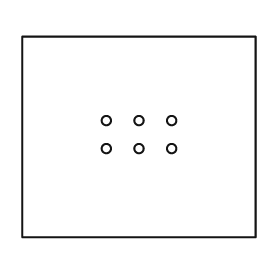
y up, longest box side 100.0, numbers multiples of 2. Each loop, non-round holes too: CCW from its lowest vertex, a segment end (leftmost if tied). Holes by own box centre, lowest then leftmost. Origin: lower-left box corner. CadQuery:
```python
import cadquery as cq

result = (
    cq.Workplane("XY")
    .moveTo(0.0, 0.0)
    .lineTo(100.0, 0.0)
    .lineTo(100.0, 86.0)
    .lineTo(0.0, 86.0)
    .close()
    .moveTo(36.0, 38.0)
    .circle(2.0)
    .moveTo(50.0, 38.0)
    .circle(2.0)
    .moveTo(64.0, 38.0)
    .circle(2.0)
    .moveTo(36.0, 50.0)
    .circle(2.0)
    .moveTo(50.0, 50.0)
    .circle(2.0)
    .moveTo(64.0, 50.0)
    .circle(2.0)
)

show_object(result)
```